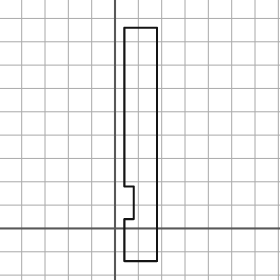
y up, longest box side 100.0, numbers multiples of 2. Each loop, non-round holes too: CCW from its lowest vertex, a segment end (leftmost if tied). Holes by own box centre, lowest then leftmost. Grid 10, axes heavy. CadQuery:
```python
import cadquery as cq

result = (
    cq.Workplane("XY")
    .moveTo(4.0, -14.0)
    .lineTo(18.0, -14.0)
    .lineTo(18.0, 86.0)
    .lineTo(4.0, 86.0)
    .lineTo(4.0, 18.0)
    .lineTo(8.0, 18.0)
    .lineTo(8.0, 4.0)
    .lineTo(4.0, 4.0)
    .close()
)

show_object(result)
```